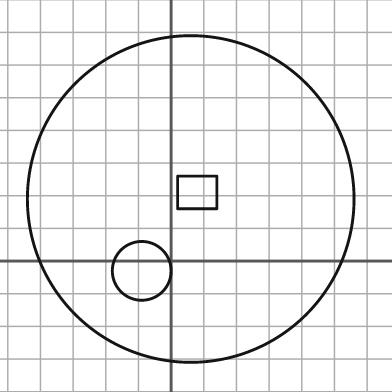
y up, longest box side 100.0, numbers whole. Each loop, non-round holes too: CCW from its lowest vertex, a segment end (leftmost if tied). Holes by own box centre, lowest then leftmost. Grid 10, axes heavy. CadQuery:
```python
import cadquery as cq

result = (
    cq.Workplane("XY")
    .moveTo(6.0, 19.0)
    .circle(50.0)
    .moveTo(-9.0, -3.0)
    .circle(9.0)
    .moveTo(2.0, 16.0)
    .lineTo(14.0, 16.0)
    .lineTo(14.0, 26.0)
    .lineTo(2.0, 26.0)
    .close()
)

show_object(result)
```